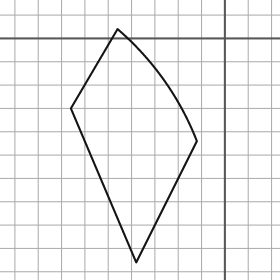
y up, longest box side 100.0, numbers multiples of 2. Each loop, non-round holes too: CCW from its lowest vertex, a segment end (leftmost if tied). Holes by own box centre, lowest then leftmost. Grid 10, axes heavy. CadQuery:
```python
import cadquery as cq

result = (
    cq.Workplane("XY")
    .moveTo(-38.0, -96.0)
    .lineTo(-12.0, -44.0)
    .threePointArc((-26.0, -18.0), (-46.0, 4.0))
    .lineTo(-66.0, -30.0)
    .close()
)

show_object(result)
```